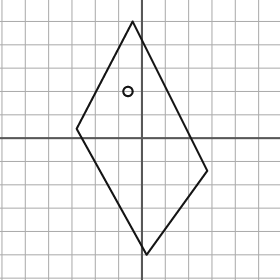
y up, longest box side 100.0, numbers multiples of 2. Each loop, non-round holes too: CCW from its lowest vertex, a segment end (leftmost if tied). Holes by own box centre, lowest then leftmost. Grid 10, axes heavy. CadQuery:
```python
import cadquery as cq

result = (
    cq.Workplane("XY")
    .moveTo(2.0, -50.0)
    .lineTo(28.0, -14.0)
    .lineTo(-4.0, 50.0)
    .lineTo(-28.0, 4.0)
    .close()
    .moveTo(-6.0, 20.0)
    .circle(2.0)
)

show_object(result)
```